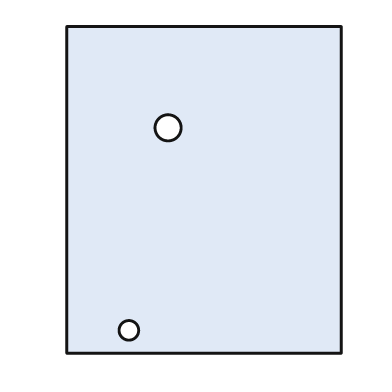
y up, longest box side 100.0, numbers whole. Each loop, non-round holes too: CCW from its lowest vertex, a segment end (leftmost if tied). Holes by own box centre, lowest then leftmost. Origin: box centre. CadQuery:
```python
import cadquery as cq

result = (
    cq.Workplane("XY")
    .moveTo(-42.0, -50.0)
    .lineTo(42.0, -50.0)
    .lineTo(42.0, 50.0)
    .lineTo(-42.0, 50.0)
    .close()
    .moveTo(-23.0, -43.0)
    .circle(3.0)
    .moveTo(-11.0, 19.0)
    .circle(4.0)
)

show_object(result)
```